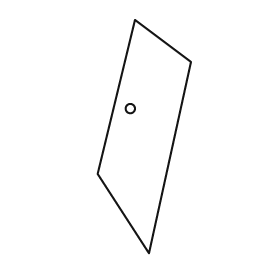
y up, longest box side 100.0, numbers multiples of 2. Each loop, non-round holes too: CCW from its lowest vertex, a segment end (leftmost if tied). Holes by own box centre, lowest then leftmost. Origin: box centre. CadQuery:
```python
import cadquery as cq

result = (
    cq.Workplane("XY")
    .moveTo(2.0, -50.0)
    .lineTo(20.0, 32.0)
    .lineTo(-4.0, 50.0)
    .lineTo(-20.0, -16.0)
    .close()
    .moveTo(-6.0, 12.0)
    .circle(2.0)
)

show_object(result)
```